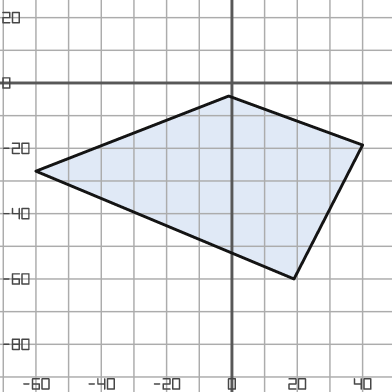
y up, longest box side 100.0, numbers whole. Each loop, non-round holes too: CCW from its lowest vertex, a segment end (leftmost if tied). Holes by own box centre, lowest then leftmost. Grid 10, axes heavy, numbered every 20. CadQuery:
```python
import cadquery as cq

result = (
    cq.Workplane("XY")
    .moveTo(19.0, -60.0)
    .lineTo(40.0, -19.0)
    .lineTo(-1.0, -4.0)
    .lineTo(-60.0, -27.0)
    .close()
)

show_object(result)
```